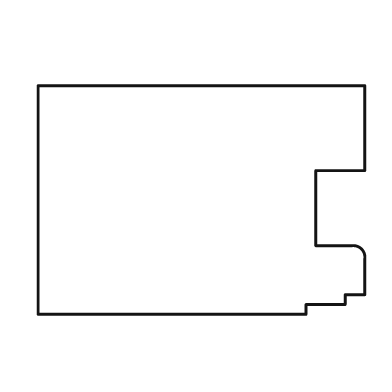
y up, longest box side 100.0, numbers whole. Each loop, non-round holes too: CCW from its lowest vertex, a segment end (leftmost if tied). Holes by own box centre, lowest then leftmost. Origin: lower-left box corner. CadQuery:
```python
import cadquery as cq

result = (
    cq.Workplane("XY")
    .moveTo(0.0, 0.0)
    .lineTo(82.0, 0.0)
    .lineTo(82.0, 3.0)
    .lineTo(94.0, 3.0)
    .lineTo(94.0, 6.0)
    .lineTo(100.0, 6.0)
    .lineTo(100.0, 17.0)
    .threePointArc((99.0, 20.0), (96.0, 21.0))
    .lineTo(85.0, 21.0)
    .lineTo(85.0, 44.0)
    .lineTo(100.0, 44.0)
    .lineTo(100.0, 70.0)
    .lineTo(0.0, 70.0)
    .close()
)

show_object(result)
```